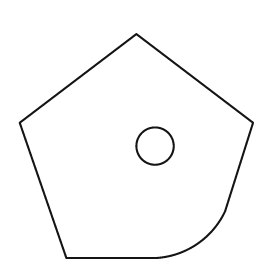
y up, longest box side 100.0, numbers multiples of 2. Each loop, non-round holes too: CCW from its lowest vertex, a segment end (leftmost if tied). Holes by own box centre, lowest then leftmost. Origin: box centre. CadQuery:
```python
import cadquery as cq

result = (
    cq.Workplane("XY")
    .moveTo(-30.0, -48.0)
    .lineTo(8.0, -48.0)
    .threePointArc((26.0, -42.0), (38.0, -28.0))
    .lineTo(50.0, 10.0)
    .lineTo(0.0, 48.0)
    .lineTo(-50.0, 10.0)
    .close()
    .moveTo(8.0, 0.0)
    .circle(8.0)
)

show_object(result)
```